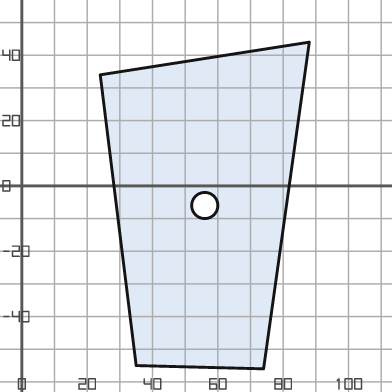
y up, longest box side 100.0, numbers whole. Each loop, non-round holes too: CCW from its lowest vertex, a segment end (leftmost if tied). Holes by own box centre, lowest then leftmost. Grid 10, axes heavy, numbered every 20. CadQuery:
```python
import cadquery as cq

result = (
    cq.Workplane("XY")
    .moveTo(74.0, -56.0)
    .lineTo(88.0, 44.0)
    .lineTo(24.0, 34.0)
    .lineTo(35.0, -55.0)
    .close()
    .moveTo(56.0, -6.0)
    .circle(4.0)
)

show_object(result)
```